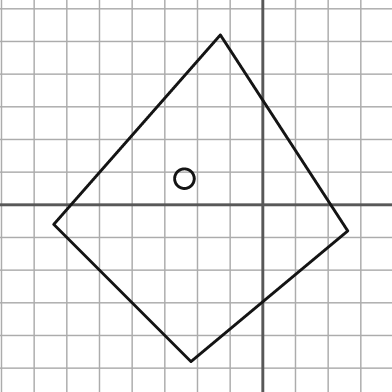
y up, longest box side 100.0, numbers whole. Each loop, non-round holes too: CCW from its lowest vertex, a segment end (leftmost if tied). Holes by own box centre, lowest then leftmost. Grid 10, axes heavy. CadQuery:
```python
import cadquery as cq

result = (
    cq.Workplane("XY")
    .moveTo(-22.0, -48.0)
    .lineTo(26.0, -8.0)
    .lineTo(-13.0, 52.0)
    .lineTo(-64.0, -6.0)
    .close()
    .moveTo(-24.0, 8.0)
    .circle(3.0)
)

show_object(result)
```